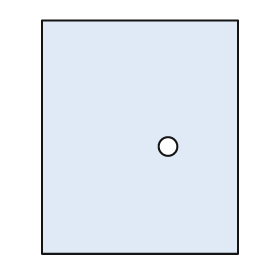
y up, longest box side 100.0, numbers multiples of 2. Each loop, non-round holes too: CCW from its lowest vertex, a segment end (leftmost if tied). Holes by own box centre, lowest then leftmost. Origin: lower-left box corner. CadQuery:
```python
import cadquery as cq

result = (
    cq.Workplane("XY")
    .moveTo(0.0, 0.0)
    .lineTo(84.0, 0.0)
    .lineTo(84.0, 100.0)
    .lineTo(0.0, 100.0)
    .close()
    .moveTo(54.0, 46.0)
    .circle(4.0)
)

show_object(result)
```